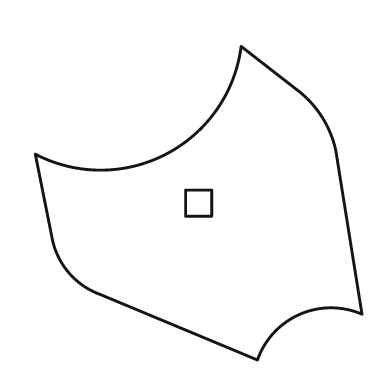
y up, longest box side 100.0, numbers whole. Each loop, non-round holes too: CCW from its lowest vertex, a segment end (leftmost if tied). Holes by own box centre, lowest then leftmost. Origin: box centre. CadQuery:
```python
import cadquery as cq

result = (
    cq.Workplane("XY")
    .moveTo(18.0, -48.0)
    .threePointArc((31.0, -34.0), (50.0, -34.0))
    .lineTo(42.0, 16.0)
    .threePointArc((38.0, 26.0), (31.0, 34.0))
    .lineTo(13.0, 48.0)
    .threePointArc((-10.0, 15.0), (-50.0, 15.0))
    .lineTo(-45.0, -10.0)
    .threePointArc((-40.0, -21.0), (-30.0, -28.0))
    .close()
    .moveTo(-4.0, -4.0)
    .lineTo(4.0, -4.0)
    .lineTo(4.0, 4.0)
    .lineTo(-4.0, 4.0)
    .close()
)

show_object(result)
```